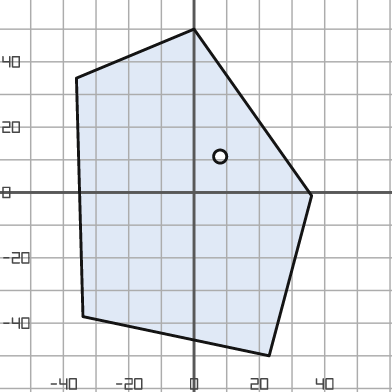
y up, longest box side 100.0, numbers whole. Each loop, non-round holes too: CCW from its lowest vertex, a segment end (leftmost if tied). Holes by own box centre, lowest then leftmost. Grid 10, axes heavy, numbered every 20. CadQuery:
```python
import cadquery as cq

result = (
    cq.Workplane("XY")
    .moveTo(23.0, -50.0)
    .lineTo(36.0, -1.0)
    .lineTo(0.0, 50.0)
    .lineTo(-36.0, 35.0)
    .lineTo(-34.0, -38.0)
    .close()
    .moveTo(8.0, 11.0)
    .circle(2.0)
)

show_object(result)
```